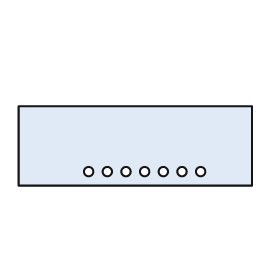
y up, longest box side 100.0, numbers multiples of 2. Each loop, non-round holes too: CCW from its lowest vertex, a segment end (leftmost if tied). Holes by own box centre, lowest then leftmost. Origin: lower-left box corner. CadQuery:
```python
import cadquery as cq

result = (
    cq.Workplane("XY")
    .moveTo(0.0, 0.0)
    .lineTo(100.0, 0.0)
    .lineTo(100.0, 34.0)
    .lineTo(0.0, 34.0)
    .close()
    .moveTo(30.0, 6.0)
    .circle(2.0)
    .moveTo(38.0, 6.0)
    .circle(2.0)
    .moveTo(46.0, 6.0)
    .circle(2.0)
    .moveTo(54.0, 6.0)
    .circle(2.0)
    .moveTo(62.0, 6.0)
    .circle(2.0)
    .moveTo(70.0, 6.0)
    .circle(2.0)
    .moveTo(78.0, 6.0)
    .circle(2.0)
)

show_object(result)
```